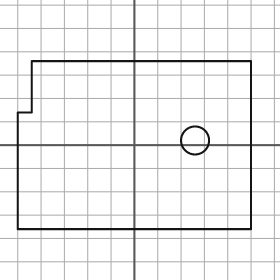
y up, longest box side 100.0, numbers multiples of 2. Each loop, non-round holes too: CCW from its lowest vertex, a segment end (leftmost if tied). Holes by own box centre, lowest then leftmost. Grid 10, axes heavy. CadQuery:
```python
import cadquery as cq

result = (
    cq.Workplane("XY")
    .moveTo(-50.0, -36.0)
    .lineTo(50.0, -36.0)
    .lineTo(50.0, 36.0)
    .lineTo(-44.0, 36.0)
    .lineTo(-44.0, 14.0)
    .lineTo(-50.0, 14.0)
    .close()
    .moveTo(26.0, 2.0)
    .circle(6.0)
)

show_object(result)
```